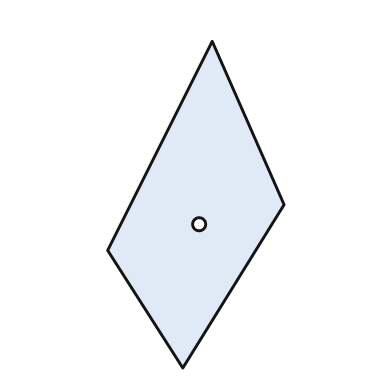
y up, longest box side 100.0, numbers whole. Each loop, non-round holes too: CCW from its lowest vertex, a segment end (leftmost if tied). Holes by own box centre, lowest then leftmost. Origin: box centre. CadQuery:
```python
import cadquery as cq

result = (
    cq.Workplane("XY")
    .moveTo(-4.0, -50.0)
    .lineTo(27.0, 0.0)
    .lineTo(5.0, 50.0)
    .lineTo(-27.0, -14.0)
    .close()
    .moveTo(1.0, -6.0)
    .circle(2.0)
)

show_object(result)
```